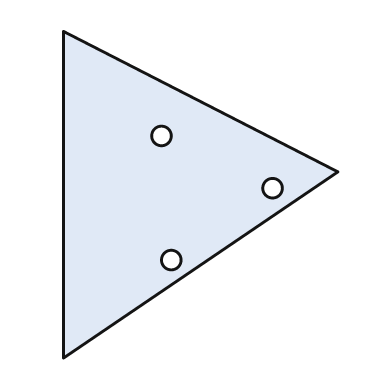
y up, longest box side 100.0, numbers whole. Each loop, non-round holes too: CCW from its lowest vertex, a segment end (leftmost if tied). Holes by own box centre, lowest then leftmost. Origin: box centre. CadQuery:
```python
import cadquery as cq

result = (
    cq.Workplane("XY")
    .moveTo(-42.0, -50.0)
    .lineTo(42.0, 7.0)
    .lineTo(-42.0, 50.0)
    .close()
    .moveTo(-9.0, -20.0)
    .circle(3.0)
    .moveTo(22.0, 2.0)
    .circle(3.0)
    .moveTo(-12.0, 18.0)
    .circle(3.0)
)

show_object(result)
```